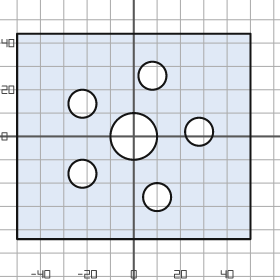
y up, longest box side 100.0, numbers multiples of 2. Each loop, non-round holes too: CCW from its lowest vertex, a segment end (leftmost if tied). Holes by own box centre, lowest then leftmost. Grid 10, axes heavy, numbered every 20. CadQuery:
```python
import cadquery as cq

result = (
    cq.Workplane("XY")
    .moveTo(-50.0, -44.0)
    .lineTo(50.0, -44.0)
    .lineTo(50.0, 44.0)
    .lineTo(-50.0, 44.0)
    .close()
    .moveTo(10.0, -26.0)
    .circle(6.0)
    .moveTo(-22.0, -16.0)
    .circle(6.0)
    .moveTo(0.0, 0.0)
    .circle(10.0)
    .moveTo(28.0, 2.0)
    .circle(6.0)
    .moveTo(-22.0, 14.0)
    .circle(6.0)
    .moveTo(8.0, 26.0)
    .circle(6.0)
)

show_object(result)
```